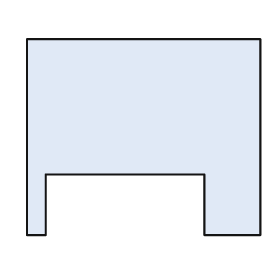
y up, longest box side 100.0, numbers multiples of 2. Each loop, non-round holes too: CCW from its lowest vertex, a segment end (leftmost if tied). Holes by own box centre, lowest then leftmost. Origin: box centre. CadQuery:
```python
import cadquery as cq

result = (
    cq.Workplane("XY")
    .moveTo(-50.0, -42.0)
    .lineTo(-42.0, -42.0)
    .lineTo(-42.0, -16.0)
    .lineTo(26.0, -16.0)
    .lineTo(26.0, -42.0)
    .lineTo(50.0, -42.0)
    .lineTo(50.0, 42.0)
    .lineTo(-50.0, 42.0)
    .close()
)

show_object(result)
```